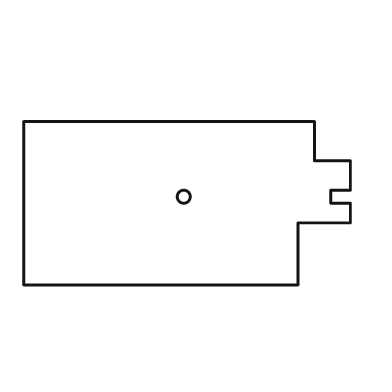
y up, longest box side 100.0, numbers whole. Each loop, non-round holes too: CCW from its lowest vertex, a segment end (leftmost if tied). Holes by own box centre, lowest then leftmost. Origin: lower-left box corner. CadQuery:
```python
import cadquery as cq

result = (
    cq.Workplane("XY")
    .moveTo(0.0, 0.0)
    .lineTo(84.0, 0.0)
    .lineTo(84.0, 19.0)
    .lineTo(100.0, 19.0)
    .lineTo(100.0, 25.0)
    .lineTo(94.0, 25.0)
    .lineTo(94.0, 29.0)
    .lineTo(100.0, 29.0)
    .lineTo(100.0, 38.0)
    .lineTo(89.0, 38.0)
    .lineTo(89.0, 50.0)
    .lineTo(0.0, 50.0)
    .close()
    .moveTo(49.0, 27.0)
    .circle(2.0)
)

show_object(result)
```